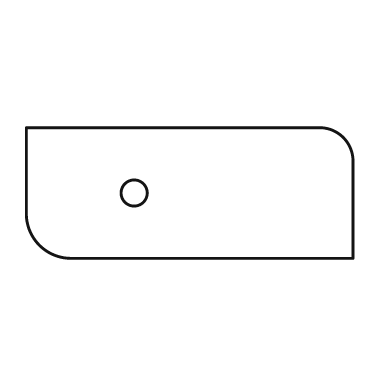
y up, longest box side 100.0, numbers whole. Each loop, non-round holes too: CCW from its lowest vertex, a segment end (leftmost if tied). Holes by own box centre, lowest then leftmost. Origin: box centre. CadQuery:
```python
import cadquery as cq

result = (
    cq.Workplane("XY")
    .moveTo(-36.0, -20.0)
    .lineTo(50.0, -20.0)
    .lineTo(50.0, 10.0)
    .threePointArc((47.0, 17.0), (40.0, 20.0))
    .lineTo(-50.0, 20.0)
    .lineTo(-50.0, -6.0)
    .threePointArc((-46.0, -16.0), (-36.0, -20.0))
    .close()
    .moveTo(-17.0, 0.0)
    .circle(4.0)
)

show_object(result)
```